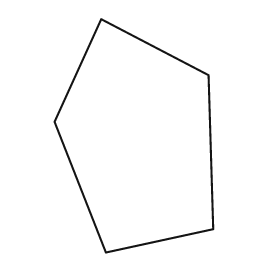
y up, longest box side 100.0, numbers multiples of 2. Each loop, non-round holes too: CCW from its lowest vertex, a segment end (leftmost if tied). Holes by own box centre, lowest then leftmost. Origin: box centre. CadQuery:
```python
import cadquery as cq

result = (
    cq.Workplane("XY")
    .moveTo(-12.0, -50.0)
    .lineTo(34.0, -40.0)
    .lineTo(32.0, 26.0)
    .lineTo(-14.0, 50.0)
    .lineTo(-34.0, 6.0)
    .close()
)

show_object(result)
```